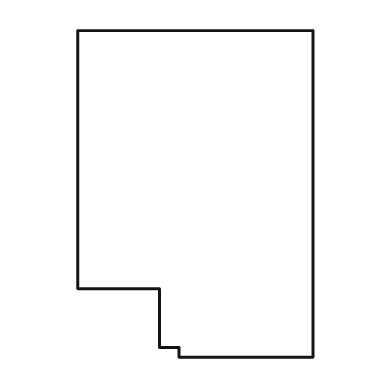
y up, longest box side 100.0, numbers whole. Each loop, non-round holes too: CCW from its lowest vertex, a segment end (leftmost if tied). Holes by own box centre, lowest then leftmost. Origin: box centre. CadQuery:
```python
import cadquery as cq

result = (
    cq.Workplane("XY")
    .moveTo(-5.0, -50.0)
    .lineTo(36.0, -50.0)
    .lineTo(36.0, 50.0)
    .lineTo(-36.0, 50.0)
    .lineTo(-36.0, -29.0)
    .lineTo(-11.0, -29.0)
    .lineTo(-11.0, -47.0)
    .lineTo(-5.0, -47.0)
    .close()
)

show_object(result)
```